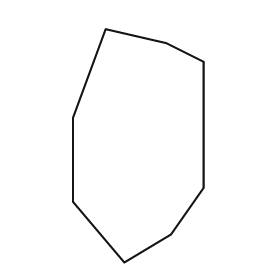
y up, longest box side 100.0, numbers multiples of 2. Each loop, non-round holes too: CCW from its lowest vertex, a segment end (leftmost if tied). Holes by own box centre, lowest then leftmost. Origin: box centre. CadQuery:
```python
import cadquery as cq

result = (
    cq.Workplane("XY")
    .moveTo(-6.0, -50.0)
    .lineTo(14.0, -38.0)
    .lineTo(28.0, -18.0)
    .lineTo(28.0, 36.0)
    .lineTo(12.0, 44.0)
    .lineTo(-14.0, 50.0)
    .lineTo(-28.0, 12.0)
    .lineTo(-28.0, -24.0)
    .close()
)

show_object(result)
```